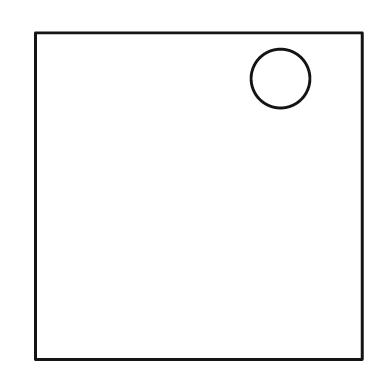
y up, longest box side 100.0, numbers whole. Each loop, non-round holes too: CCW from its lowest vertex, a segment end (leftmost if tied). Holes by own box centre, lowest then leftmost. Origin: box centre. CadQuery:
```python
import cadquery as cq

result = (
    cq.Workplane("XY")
    .moveTo(-50.0, -50.0)
    .lineTo(50.0, -50.0)
    .lineTo(50.0, 50.0)
    .lineTo(-50.0, 50.0)
    .close()
    .moveTo(25.0, 36.0)
    .circle(9.0)
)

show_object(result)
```